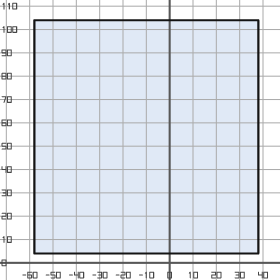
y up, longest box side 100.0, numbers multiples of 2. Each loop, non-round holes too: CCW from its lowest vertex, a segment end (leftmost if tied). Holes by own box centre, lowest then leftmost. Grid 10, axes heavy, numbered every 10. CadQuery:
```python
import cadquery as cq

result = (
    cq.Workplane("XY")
    .moveTo(-58.0, 4.0)
    .lineTo(38.0, 4.0)
    .lineTo(38.0, 104.0)
    .lineTo(-58.0, 104.0)
    .close()
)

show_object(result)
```